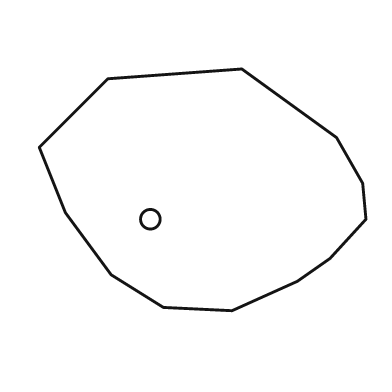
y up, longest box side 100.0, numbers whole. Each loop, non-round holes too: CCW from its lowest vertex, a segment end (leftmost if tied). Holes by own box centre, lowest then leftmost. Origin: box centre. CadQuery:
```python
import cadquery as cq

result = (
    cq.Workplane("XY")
    .moveTo(9.0, -37.0)
    .lineTo(29.0, -28.0)
    .lineTo(39.0, -21.0)
    .lineTo(50.0, -9.0)
    .lineTo(49.0, 2.0)
    .lineTo(41.0, 16.0)
    .lineTo(12.0, 37.0)
    .lineTo(-29.0, 34.0)
    .lineTo(-50.0, 13.0)
    .lineTo(-42.0, -7.0)
    .lineTo(-28.0, -26.0)
    .lineTo(-12.0, -36.0)
    .close()
    .moveTo(-16.0, -9.0)
    .circle(3.0)
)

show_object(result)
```